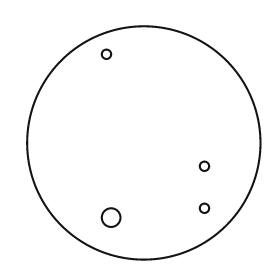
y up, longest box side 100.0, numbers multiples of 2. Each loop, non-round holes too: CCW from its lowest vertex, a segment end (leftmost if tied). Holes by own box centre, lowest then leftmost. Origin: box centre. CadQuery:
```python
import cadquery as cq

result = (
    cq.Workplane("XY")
    .moveTo(0.0, 0.0)
    .circle(50.0)
    .moveTo(-14.0, -32.0)
    .circle(4.0)
    .moveTo(26.0, -28.0)
    .circle(2.0)
    .moveTo(26.0, -10.0)
    .circle(2.0)
    .moveTo(-16.0, 38.0)
    .circle(2.0)
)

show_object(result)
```